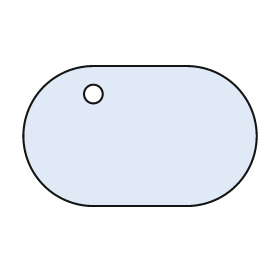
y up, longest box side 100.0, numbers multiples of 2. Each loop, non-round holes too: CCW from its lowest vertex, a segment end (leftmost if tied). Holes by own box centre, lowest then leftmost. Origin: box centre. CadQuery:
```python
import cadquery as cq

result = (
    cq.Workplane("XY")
    .moveTo(-20.0, -30.0)
    .lineTo(20.0, -30.0)
    .threePointArc((50.0, 0.0), (20.0, 30.0))
    .lineTo(-20.0, 30.0)
    .threePointArc((-50.0, 0.0), (-20.0, -30.0))
    .close()
    .moveTo(-20.0, 18.0)
    .circle(4.0)
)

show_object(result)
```